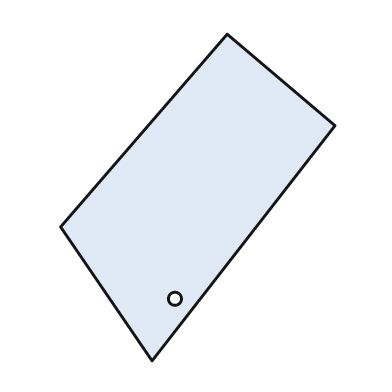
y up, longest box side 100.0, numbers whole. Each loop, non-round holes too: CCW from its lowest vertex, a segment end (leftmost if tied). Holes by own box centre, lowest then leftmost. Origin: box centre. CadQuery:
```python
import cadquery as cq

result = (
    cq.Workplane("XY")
    .moveTo(-14.0, -50.0)
    .lineTo(42.0, 22.0)
    .lineTo(9.0, 50.0)
    .lineTo(-42.0, -9.0)
    .close()
    .moveTo(-7.0, -31.0)
    .circle(2.0)
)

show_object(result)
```